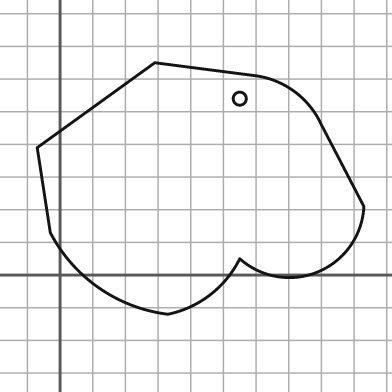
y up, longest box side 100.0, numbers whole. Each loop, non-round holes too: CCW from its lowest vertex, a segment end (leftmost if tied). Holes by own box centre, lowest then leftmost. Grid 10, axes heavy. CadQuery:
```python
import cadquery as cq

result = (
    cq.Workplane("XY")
    .moveTo(33.0, -12.0)
    .threePointArc((46.0, -6.0), (55.0, 5.0))
    .threePointArc((79.0, 1.0), (93.0, 21.0))
    .lineTo(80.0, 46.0)
    .threePointArc((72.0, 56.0), (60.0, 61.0))
    .lineTo(29.0, 65.0)
    .lineTo(-7.0, 39.0)
    .lineTo(-3.0, 13.0)
    .threePointArc((12.0, -4.0), (33.0, -12.0))
    .close()
    .moveTo(55.0, 54.0)
    .circle(2.0)
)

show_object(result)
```